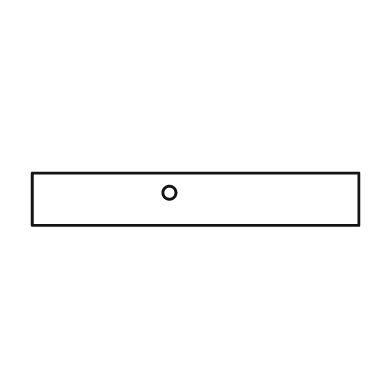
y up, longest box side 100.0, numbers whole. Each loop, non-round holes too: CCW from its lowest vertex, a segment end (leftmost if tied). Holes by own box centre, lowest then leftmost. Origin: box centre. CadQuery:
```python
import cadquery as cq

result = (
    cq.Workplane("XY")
    .moveTo(-50.0, -8.0)
    .lineTo(50.0, -8.0)
    .lineTo(50.0, 8.0)
    .lineTo(-50.0, 8.0)
    .close()
    .moveTo(-8.0, 2.0)
    .circle(2.0)
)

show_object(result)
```